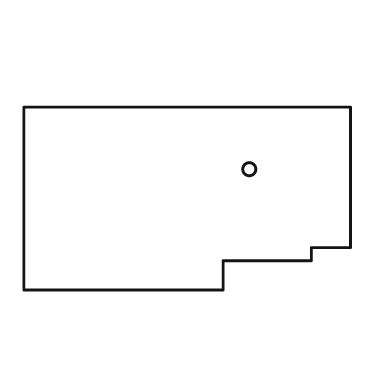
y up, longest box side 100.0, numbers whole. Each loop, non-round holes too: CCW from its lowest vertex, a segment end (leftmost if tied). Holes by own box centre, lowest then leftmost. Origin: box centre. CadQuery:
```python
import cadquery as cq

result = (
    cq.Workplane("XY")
    .moveTo(-50.0, -28.0)
    .lineTo(11.0, -28.0)
    .lineTo(11.0, -19.0)
    .lineTo(38.0, -19.0)
    .lineTo(38.0, -15.0)
    .lineTo(50.0, -15.0)
    .lineTo(50.0, 28.0)
    .lineTo(-50.0, 28.0)
    .close()
    .moveTo(19.0, 9.0)
    .circle(2.0)
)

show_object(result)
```